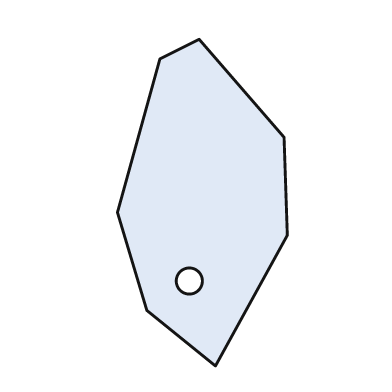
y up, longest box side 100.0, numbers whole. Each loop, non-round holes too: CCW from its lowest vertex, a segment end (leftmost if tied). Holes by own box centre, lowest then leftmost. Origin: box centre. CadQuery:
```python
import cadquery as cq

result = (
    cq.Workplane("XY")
    .moveTo(4.0, -50.0)
    .lineTo(26.0, -10.0)
    .lineTo(25.0, 20.0)
    .lineTo(-1.0, 50.0)
    .lineTo(-13.0, 44.0)
    .lineTo(-26.0, -3.0)
    .lineTo(-17.0, -33.0)
    .close()
    .moveTo(-4.0, -24.0)
    .circle(4.0)
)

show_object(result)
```